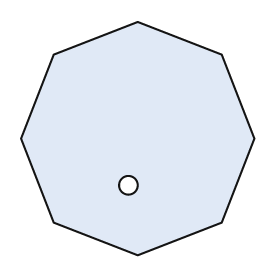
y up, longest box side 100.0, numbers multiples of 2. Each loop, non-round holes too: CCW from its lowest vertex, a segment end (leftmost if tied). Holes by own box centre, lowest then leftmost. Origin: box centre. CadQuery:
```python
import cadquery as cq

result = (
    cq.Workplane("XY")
    .moveTo(0.0, -50.0)
    .lineTo(36.0, -36.0)
    .lineTo(50.0, 0.0)
    .lineTo(36.0, 36.0)
    .lineTo(0.0, 50.0)
    .lineTo(-36.0, 36.0)
    .lineTo(-50.0, 0.0)
    .lineTo(-36.0, -36.0)
    .close()
    .moveTo(-4.0, -20.0)
    .circle(4.0)
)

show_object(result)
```